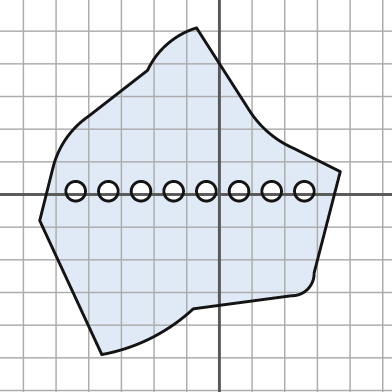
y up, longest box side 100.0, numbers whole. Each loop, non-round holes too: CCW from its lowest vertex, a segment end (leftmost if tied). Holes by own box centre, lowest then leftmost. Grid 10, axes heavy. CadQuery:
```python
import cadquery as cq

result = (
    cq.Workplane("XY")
    .moveTo(-36.0, -49.0)
    .threePointArc((-21.0, -44.0), (-8.0, -35.0))
    .lineTo(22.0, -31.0)
    .threePointArc((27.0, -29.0), (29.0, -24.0))
    .lineTo(37.0, 7.0)
    .lineTo(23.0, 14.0)
    .threePointArc((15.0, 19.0), (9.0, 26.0))
    .lineTo(-7.0, 51.0)
    .threePointArc((-16.0, 46.0), (-22.0, 38.0))
    .lineTo(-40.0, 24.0)
    .threePointArc((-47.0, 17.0), (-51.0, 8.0))
    .lineTo(-55.0, -8.0)
    .close()
    .moveTo(-44.0, 1.0)
    .circle(3.0)
    .moveTo(-34.0, 1.0)
    .circle(3.0)
    .moveTo(-24.0, 1.0)
    .circle(3.0)
    .moveTo(-14.0, 1.0)
    .circle(3.0)
    .moveTo(-4.0, 1.0)
    .circle(3.0)
    .moveTo(6.0, 1.0)
    .circle(3.0)
    .moveTo(16.0, 1.0)
    .circle(3.0)
    .moveTo(26.0, 1.0)
    .circle(3.0)
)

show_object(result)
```